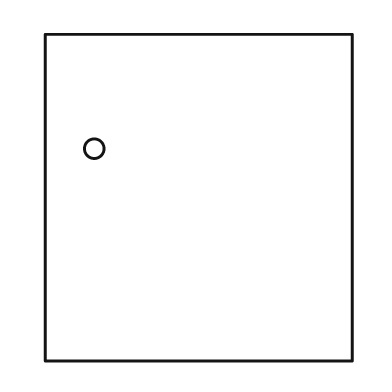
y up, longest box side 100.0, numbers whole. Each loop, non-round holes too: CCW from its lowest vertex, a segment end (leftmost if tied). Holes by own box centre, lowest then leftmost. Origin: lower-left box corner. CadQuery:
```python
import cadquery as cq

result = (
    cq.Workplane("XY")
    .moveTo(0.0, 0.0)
    .lineTo(94.0, 0.0)
    .lineTo(94.0, 100.0)
    .lineTo(0.0, 100.0)
    .close()
    .moveTo(15.0, 65.0)
    .circle(3.0)
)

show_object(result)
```